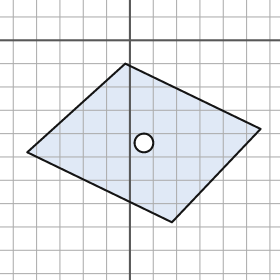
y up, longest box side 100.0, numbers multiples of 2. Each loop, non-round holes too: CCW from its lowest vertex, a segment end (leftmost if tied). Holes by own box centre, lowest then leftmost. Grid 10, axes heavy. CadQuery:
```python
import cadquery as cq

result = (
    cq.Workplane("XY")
    .moveTo(18.0, -78.0)
    .lineTo(56.0, -38.0)
    .lineTo(-2.0, -10.0)
    .lineTo(-44.0, -48.0)
    .close()
    .moveTo(6.0, -44.0)
    .circle(4.0)
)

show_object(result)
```